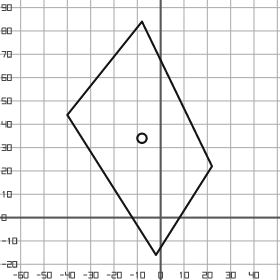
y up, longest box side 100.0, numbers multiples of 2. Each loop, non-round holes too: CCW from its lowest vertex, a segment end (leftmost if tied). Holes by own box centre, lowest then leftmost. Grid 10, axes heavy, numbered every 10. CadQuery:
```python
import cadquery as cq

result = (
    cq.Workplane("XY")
    .moveTo(-2.0, -16.0)
    .lineTo(22.0, 22.0)
    .lineTo(-8.0, 84.0)
    .lineTo(-40.0, 44.0)
    .close()
    .moveTo(-8.0, 34.0)
    .circle(2.0)
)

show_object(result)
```